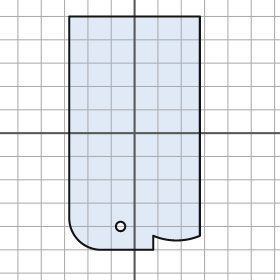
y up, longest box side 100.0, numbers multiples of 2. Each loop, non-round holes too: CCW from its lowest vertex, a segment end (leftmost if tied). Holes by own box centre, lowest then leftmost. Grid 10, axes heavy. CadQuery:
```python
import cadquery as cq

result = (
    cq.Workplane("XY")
    .moveTo(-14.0, -50.0)
    .lineTo(8.0, -50.0)
    .lineTo(8.0, -44.0)
    .threePointArc((18.0, -46.0), (28.0, -44.0))
    .lineTo(28.0, 50.0)
    .lineTo(-28.0, 50.0)
    .lineTo(-28.0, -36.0)
    .threePointArc((-24.0, -46.0), (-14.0, -50.0))
    .close()
    .moveTo(-6.0, -40.0)
    .circle(2.0)
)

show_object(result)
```